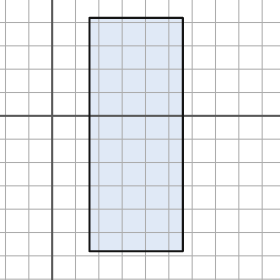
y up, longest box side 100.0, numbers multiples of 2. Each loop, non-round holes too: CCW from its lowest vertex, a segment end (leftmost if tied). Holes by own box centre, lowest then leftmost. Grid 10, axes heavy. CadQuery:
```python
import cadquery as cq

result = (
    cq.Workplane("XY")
    .moveTo(16.0, -58.0)
    .lineTo(56.0, -58.0)
    .lineTo(56.0, 42.0)
    .lineTo(16.0, 42.0)
    .close()
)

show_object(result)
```